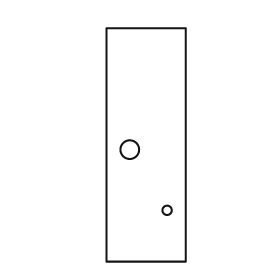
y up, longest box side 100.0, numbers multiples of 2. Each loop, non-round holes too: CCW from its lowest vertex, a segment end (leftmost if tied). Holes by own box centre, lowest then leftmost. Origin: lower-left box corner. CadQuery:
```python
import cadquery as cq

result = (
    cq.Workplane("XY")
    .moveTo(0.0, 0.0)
    .lineTo(34.0, 0.0)
    .lineTo(34.0, 100.0)
    .lineTo(0.0, 100.0)
    .close()
    .moveTo(26.0, 22.0)
    .circle(2.0)
    .moveTo(10.0, 48.0)
    .circle(4.0)
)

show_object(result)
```